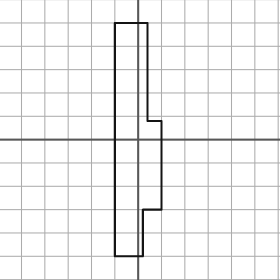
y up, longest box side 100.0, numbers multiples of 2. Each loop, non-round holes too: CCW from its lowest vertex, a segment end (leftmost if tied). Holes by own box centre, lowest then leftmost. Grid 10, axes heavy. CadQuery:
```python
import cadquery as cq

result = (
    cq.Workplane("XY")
    .moveTo(-10.0, -50.0)
    .lineTo(2.0, -50.0)
    .lineTo(2.0, -30.0)
    .lineTo(10.0, -30.0)
    .lineTo(10.0, 8.0)
    .lineTo(4.0, 8.0)
    .lineTo(4.0, 50.0)
    .lineTo(-10.0, 50.0)
    .close()
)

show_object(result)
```